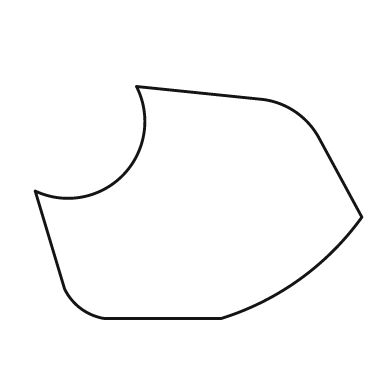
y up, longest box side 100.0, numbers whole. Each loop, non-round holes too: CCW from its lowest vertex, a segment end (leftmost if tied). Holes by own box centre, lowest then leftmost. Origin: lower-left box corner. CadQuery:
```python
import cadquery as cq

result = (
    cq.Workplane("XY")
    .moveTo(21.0, 0.0)
    .lineTo(57.0, 0.0)
    .threePointArc((81.0, 12.0), (100.0, 31.0))
    .lineTo(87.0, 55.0)
    .threePointArc((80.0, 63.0), (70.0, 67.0))
    .lineTo(31.0, 71.0)
    .threePointArc((27.0, 44.0), (0.0, 39.0))
    .lineTo(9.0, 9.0)
    .threePointArc((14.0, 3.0), (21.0, 0.0))
    .close()
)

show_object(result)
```